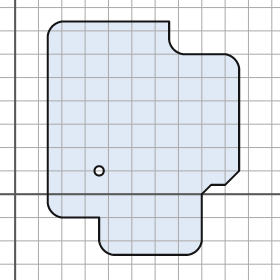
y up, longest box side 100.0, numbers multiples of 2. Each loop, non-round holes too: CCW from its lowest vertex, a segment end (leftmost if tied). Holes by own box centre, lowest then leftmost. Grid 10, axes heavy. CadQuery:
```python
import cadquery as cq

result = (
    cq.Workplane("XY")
    .moveTo(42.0, -26.0)
    .lineTo(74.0, -26.0)
    .threePointArc((78.0, -24.0), (80.0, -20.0))
    .lineTo(80.0, 0.0)
    .lineTo(84.0, 4.0)
    .lineTo(90.0, 4.0)
    .lineTo(96.0, 10.0)
    .lineTo(96.0, 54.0)
    .threePointArc((94.0, 58.0), (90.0, 60.0))
    .lineTo(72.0, 60.0)
    .threePointArc((68.0, 62.0), (66.0, 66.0))
    .lineTo(66.0, 74.0)
    .lineTo(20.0, 74.0)
    .threePointArc((16.0, 72.0), (14.0, 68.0))
    .lineTo(14.0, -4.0)
    .threePointArc((16.0, -8.0), (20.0, -10.0))
    .lineTo(36.0, -10.0)
    .lineTo(36.0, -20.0)
    .threePointArc((38.0, -24.0), (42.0, -26.0))
    .close()
    .moveTo(36.0, 10.0)
    .circle(2.0)
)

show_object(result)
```